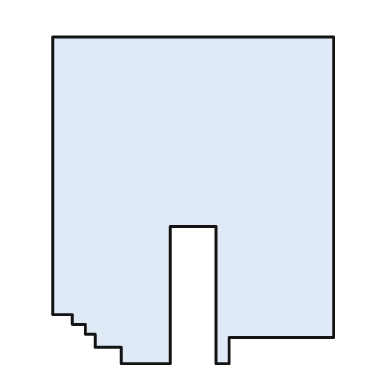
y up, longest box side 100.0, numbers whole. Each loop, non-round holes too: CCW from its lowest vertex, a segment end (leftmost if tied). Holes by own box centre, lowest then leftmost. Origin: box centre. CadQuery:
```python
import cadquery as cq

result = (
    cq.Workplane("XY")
    .moveTo(-22.0, -50.0)
    .lineTo(-7.0, -50.0)
    .lineTo(-7.0, -8.0)
    .lineTo(7.0, -8.0)
    .lineTo(7.0, -50.0)
    .lineTo(11.0, -50.0)
    .lineTo(11.0, -42.0)
    .lineTo(43.0, -42.0)
    .lineTo(43.0, 50.0)
    .lineTo(-43.0, 50.0)
    .lineTo(-43.0, -35.0)
    .lineTo(-37.0, -35.0)
    .lineTo(-37.0, -38.0)
    .lineTo(-33.0, -38.0)
    .lineTo(-33.0, -41.0)
    .lineTo(-30.0, -41.0)
    .lineTo(-30.0, -45.0)
    .lineTo(-22.0, -45.0)
    .close()
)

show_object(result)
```